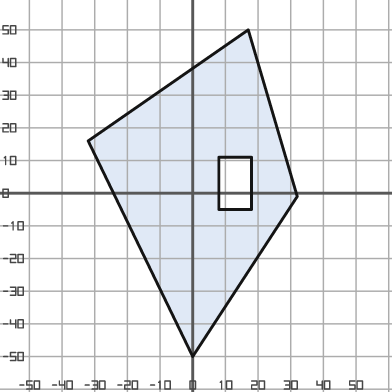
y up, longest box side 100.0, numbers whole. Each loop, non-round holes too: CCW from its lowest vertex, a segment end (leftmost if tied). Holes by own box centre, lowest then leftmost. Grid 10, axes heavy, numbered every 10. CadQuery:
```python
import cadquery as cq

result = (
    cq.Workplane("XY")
    .moveTo(0.0, -50.0)
    .lineTo(32.0, -1.0)
    .lineTo(17.0, 50.0)
    .lineTo(-32.0, 16.0)
    .close()
    .moveTo(8.0, -5.0)
    .lineTo(18.0, -5.0)
    .lineTo(18.0, 11.0)
    .lineTo(8.0, 11.0)
    .close()
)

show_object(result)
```